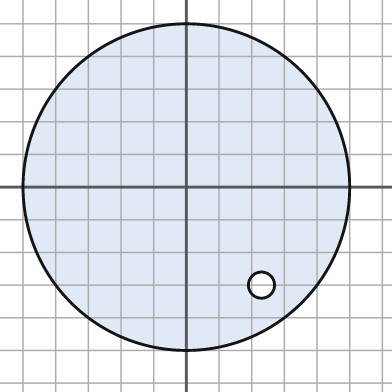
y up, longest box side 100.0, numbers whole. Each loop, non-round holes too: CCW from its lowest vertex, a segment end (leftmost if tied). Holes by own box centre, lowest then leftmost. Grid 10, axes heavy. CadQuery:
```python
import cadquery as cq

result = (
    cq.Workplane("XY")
    .moveTo(0.0, 0.0)
    .circle(50.0)
    .moveTo(23.0, -30.0)
    .circle(4.0)
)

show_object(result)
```